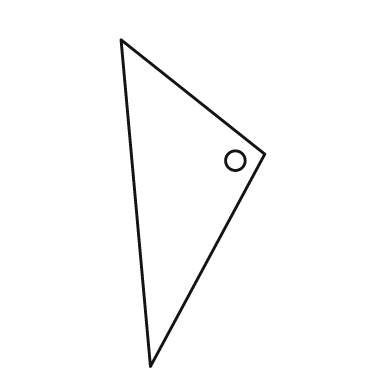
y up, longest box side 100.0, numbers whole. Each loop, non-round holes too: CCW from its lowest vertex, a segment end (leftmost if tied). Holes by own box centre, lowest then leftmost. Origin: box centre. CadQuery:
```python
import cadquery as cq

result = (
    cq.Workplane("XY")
    .moveTo(-13.0, -50.0)
    .lineTo(22.0, 15.0)
    .lineTo(-22.0, 50.0)
    .close()
    .moveTo(13.0, 13.0)
    .circle(3.0)
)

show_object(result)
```